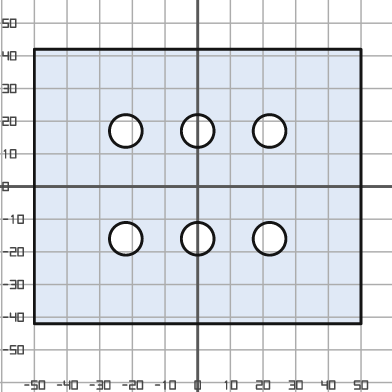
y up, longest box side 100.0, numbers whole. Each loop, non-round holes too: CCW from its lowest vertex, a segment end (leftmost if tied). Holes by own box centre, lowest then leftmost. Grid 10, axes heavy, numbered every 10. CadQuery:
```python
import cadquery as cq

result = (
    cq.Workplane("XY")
    .moveTo(-50.0, -42.0)
    .lineTo(50.0, -42.0)
    .lineTo(50.0, 42.0)
    .lineTo(-50.0, 42.0)
    .close()
    .moveTo(-22.0, -16.0)
    .circle(5.0)
    .moveTo(0.0, -16.0)
    .circle(5.0)
    .moveTo(22.0, -16.0)
    .circle(5.0)
    .moveTo(-22.0, 17.0)
    .circle(5.0)
    .moveTo(0.0, 17.0)
    .circle(5.0)
    .moveTo(22.0, 17.0)
    .circle(5.0)
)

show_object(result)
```